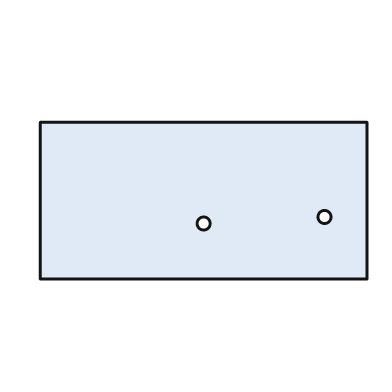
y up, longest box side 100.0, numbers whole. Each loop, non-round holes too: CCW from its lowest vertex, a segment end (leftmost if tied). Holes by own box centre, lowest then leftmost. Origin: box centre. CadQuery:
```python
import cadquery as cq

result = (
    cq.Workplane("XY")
    .moveTo(-50.0, -24.0)
    .lineTo(50.0, -24.0)
    .lineTo(50.0, 24.0)
    .lineTo(-50.0, 24.0)
    .close()
    .moveTo(0.0, -7.0)
    .circle(2.0)
    .moveTo(37.0, -5.0)
    .circle(2.0)
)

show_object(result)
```